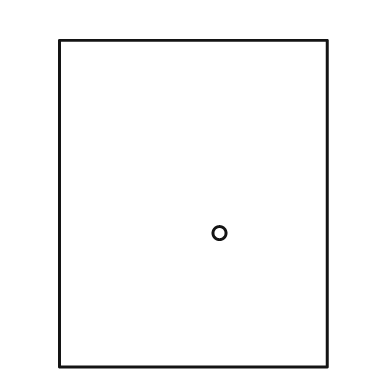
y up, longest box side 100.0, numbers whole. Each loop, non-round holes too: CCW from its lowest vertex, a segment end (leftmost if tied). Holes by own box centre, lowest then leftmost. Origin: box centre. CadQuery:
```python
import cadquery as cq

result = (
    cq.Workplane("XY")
    .moveTo(-41.0, -50.0)
    .lineTo(41.0, -50.0)
    .lineTo(41.0, 50.0)
    .lineTo(-41.0, 50.0)
    .close()
    .moveTo(8.0, -9.0)
    .circle(2.0)
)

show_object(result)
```